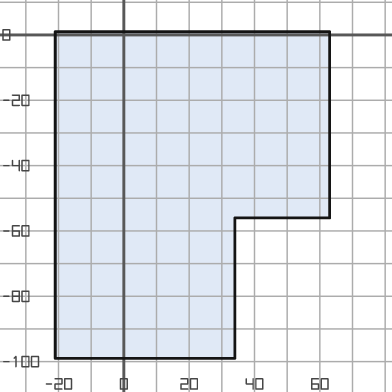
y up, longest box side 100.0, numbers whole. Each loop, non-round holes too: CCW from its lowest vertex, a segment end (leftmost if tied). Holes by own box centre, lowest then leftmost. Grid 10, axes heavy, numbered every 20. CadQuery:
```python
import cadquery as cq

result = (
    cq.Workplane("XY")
    .moveTo(-21.0, -99.0)
    .lineTo(34.0, -99.0)
    .lineTo(34.0, -56.0)
    .lineTo(63.0, -56.0)
    .lineTo(63.0, 1.0)
    .lineTo(-21.0, 1.0)
    .close()
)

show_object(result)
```